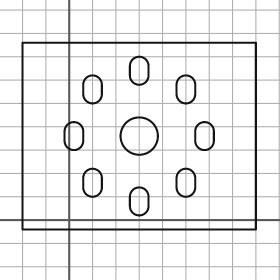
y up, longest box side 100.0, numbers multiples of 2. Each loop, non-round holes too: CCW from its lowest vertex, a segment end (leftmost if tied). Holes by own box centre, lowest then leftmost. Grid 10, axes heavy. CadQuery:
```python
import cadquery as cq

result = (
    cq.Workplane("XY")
    .moveTo(-20.0, -4.0)
    .lineTo(80.0, -4.0)
    .lineTo(80.0, 76.0)
    .lineTo(-20.0, 76.0)
    .close()
    .moveTo(26.0, 6.0)
    .threePointArc((30.0, 2.0), (34.0, 6.0))
    .lineTo(34.0, 10.0)
    .threePointArc((30.0, 14.0), (26.0, 10.0))
    .close()
    .moveTo(6.0, 14.0)
    .threePointArc((10.0, 10.0), (14.0, 14.0))
    .lineTo(14.0, 18.0)
    .threePointArc((10.0, 22.0), (6.0, 18.0))
    .close()
    .moveTo(46.0, 14.0)
    .threePointArc((50.0, 10.0), (54.0, 14.0))
    .lineTo(54.0, 18.0)
    .threePointArc((50.0, 22.0), (46.0, 18.0))
    .close()
    .moveTo(-2.0, 34.0)
    .threePointArc((2.0, 30.0), (6.0, 34.0))
    .lineTo(6.0, 38.0)
    .threePointArc((2.0, 42.0), (-2.0, 38.0))
    .close()
    .moveTo(30.0, 36.0)
    .circle(8.0)
    .moveTo(54.0, 34.0)
    .threePointArc((58.0, 30.0), (62.0, 34.0))
    .lineTo(62.0, 38.0)
    .threePointArc((58.0, 42.0), (54.0, 38.0))
    .close()
    .moveTo(6.0, 54.0)
    .threePointArc((10.0, 50.0), (14.0, 54.0))
    .lineTo(14.0, 58.0)
    .threePointArc((10.0, 62.0), (6.0, 58.0))
    .close()
    .moveTo(46.0, 54.0)
    .threePointArc((50.0, 50.0), (54.0, 54.0))
    .lineTo(54.0, 58.0)
    .threePointArc((50.0, 62.0), (46.0, 58.0))
    .close()
    .moveTo(26.0, 62.0)
    .threePointArc((30.0, 58.0), (34.0, 62.0))
    .lineTo(34.0, 66.0)
    .threePointArc((30.0, 70.0), (26.0, 66.0))
    .close()
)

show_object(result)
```